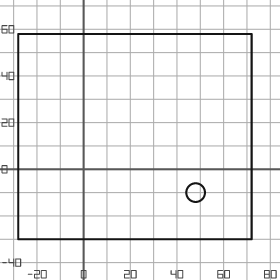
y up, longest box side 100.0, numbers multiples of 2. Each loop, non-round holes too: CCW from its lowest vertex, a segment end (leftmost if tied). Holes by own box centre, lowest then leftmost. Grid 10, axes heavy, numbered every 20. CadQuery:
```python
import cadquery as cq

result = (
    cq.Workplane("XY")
    .moveTo(-28.0, -30.0)
    .lineTo(72.0, -30.0)
    .lineTo(72.0, 58.0)
    .lineTo(-28.0, 58.0)
    .close()
    .moveTo(48.0, -10.0)
    .circle(4.0)
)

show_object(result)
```